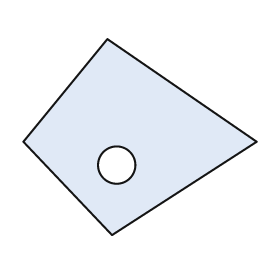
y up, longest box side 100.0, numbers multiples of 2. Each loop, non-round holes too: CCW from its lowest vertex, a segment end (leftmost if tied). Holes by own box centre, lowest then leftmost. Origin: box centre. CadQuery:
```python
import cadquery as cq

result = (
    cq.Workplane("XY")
    .moveTo(-12.0, -42.0)
    .lineTo(50.0, -2.0)
    .lineTo(-14.0, 42.0)
    .lineTo(-50.0, -2.0)
    .close()
    .moveTo(-10.0, -12.0)
    .circle(8.0)
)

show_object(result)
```